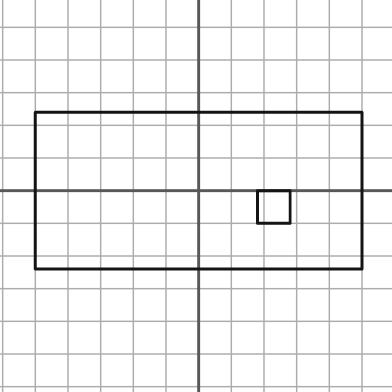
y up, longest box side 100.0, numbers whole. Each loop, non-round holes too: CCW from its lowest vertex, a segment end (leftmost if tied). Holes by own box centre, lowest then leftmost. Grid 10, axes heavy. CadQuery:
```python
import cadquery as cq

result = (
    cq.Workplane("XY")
    .moveTo(-50.0, -24.0)
    .lineTo(50.0, -24.0)
    .lineTo(50.0, 24.0)
    .lineTo(-50.0, 24.0)
    .close()
    .moveTo(18.0, -10.0)
    .lineTo(28.0, -10.0)
    .lineTo(28.0, 0.0)
    .lineTo(18.0, 0.0)
    .close()
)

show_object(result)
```